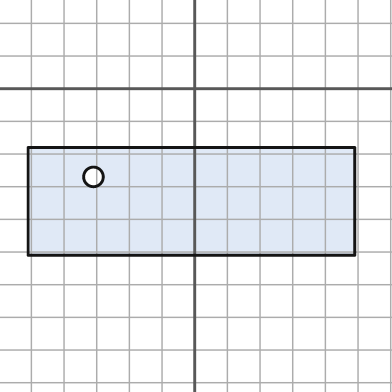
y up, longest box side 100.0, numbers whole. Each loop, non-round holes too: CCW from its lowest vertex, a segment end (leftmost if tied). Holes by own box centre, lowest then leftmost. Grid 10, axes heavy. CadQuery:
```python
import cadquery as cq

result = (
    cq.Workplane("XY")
    .moveTo(-51.0, -51.0)
    .lineTo(49.0, -51.0)
    .lineTo(49.0, -18.0)
    .lineTo(-51.0, -18.0)
    .close()
    .moveTo(-31.0, -27.0)
    .circle(3.0)
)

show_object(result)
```